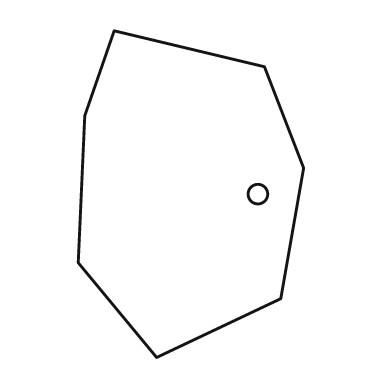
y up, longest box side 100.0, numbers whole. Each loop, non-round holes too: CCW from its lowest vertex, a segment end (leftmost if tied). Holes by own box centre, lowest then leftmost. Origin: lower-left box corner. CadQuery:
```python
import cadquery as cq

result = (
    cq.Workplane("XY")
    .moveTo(24.0, 0.0)
    .lineTo(62.0, 18.0)
    .lineTo(69.0, 58.0)
    .lineTo(57.0, 89.0)
    .lineTo(11.0, 100.0)
    .lineTo(2.0, 74.0)
    .lineTo(0.0, 29.0)
    .close()
    .moveTo(55.0, 50.0)
    .circle(3.0)
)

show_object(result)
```